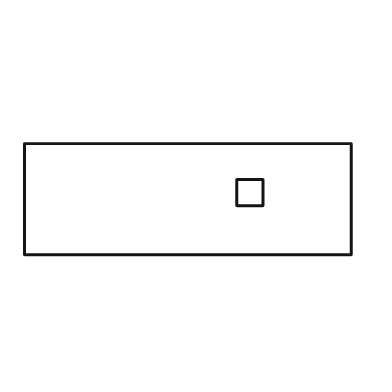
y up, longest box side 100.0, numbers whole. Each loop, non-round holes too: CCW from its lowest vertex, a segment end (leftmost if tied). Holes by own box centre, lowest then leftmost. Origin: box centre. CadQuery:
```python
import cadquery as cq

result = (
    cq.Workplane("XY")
    .moveTo(-50.0, -17.0)
    .lineTo(50.0, -17.0)
    .lineTo(50.0, 17.0)
    .lineTo(-50.0, 17.0)
    .close()
    .moveTo(15.0, -2.0)
    .lineTo(23.0, -2.0)
    .lineTo(23.0, 6.0)
    .lineTo(15.0, 6.0)
    .close()
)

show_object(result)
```